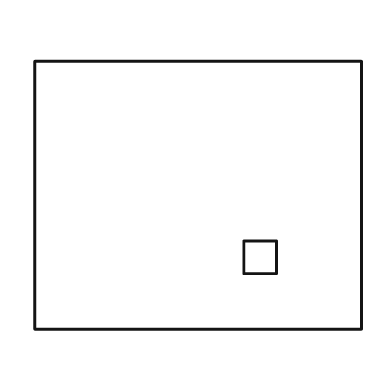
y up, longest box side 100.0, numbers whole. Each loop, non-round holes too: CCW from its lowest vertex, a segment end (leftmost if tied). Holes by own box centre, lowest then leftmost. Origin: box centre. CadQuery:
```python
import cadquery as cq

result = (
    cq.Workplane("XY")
    .moveTo(-50.0, -41.0)
    .lineTo(50.0, -41.0)
    .lineTo(50.0, 41.0)
    .lineTo(-50.0, 41.0)
    .close()
    .moveTo(14.0, -24.0)
    .lineTo(24.0, -24.0)
    .lineTo(24.0, -14.0)
    .lineTo(14.0, -14.0)
    .close()
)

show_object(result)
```